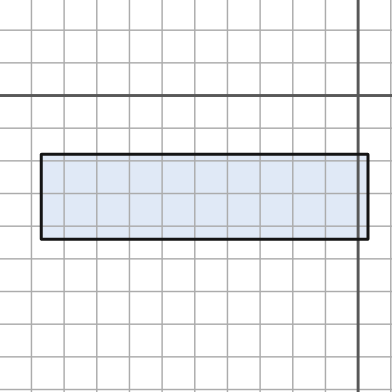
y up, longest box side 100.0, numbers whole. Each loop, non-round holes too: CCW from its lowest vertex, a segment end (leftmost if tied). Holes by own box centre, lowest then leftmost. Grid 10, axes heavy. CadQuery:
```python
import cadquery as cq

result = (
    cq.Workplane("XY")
    .moveTo(-97.0, -44.0)
    .lineTo(3.0, -44.0)
    .lineTo(3.0, -18.0)
    .lineTo(-97.0, -18.0)
    .close()
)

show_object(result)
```